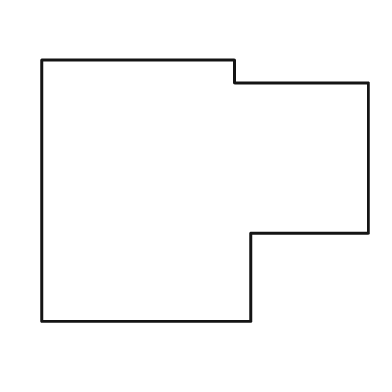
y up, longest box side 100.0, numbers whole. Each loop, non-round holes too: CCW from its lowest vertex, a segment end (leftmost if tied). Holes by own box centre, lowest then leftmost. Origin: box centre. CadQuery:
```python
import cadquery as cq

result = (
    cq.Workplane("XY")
    .moveTo(-50.0, -40.0)
    .lineTo(14.0, -40.0)
    .lineTo(14.0, -13.0)
    .lineTo(50.0, -13.0)
    .lineTo(50.0, 33.0)
    .lineTo(9.0, 33.0)
    .lineTo(9.0, 40.0)
    .lineTo(-50.0, 40.0)
    .close()
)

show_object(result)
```